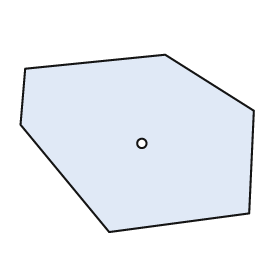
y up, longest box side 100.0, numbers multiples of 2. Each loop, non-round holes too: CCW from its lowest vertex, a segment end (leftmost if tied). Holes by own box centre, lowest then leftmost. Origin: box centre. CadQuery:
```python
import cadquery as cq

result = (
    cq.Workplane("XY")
    .moveTo(-12.0, -38.0)
    .lineTo(48.0, -30.0)
    .lineTo(50.0, 14.0)
    .lineTo(12.0, 38.0)
    .lineTo(-48.0, 32.0)
    .lineTo(-50.0, 8.0)
    .close()
    .moveTo(2.0, 0.0)
    .circle(2.0)
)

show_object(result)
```